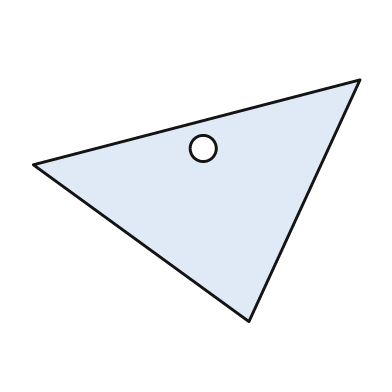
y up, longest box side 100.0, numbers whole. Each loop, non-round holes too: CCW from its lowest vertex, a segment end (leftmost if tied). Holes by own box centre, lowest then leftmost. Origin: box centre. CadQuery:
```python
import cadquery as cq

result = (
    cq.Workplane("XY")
    .moveTo(16.0, -37.0)
    .lineTo(50.0, 37.0)
    .lineTo(-50.0, 11.0)
    .close()
    .moveTo(2.0, 16.0)
    .circle(4.0)
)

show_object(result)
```